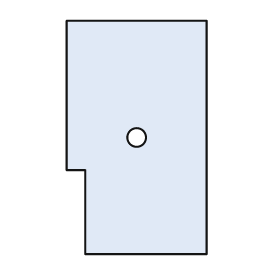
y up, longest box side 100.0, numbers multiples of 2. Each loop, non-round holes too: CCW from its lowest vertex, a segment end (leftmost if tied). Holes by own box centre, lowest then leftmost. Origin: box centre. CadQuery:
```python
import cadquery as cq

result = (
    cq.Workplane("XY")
    .moveTo(-22.0, -50.0)
    .lineTo(30.0, -50.0)
    .lineTo(30.0, 50.0)
    .lineTo(-30.0, 50.0)
    .lineTo(-30.0, -14.0)
    .lineTo(-22.0, -14.0)
    .close()
    .moveTo(0.0, 0.0)
    .circle(4.0)
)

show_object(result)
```